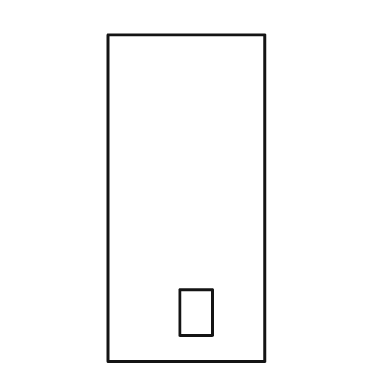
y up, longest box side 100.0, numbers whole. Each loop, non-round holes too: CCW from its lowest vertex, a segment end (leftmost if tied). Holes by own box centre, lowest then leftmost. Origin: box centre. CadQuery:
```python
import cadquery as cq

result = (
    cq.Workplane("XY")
    .moveTo(-24.0, -50.0)
    .lineTo(24.0, -50.0)
    .lineTo(24.0, 50.0)
    .lineTo(-24.0, 50.0)
    .close()
    .moveTo(-2.0, -42.0)
    .lineTo(8.0, -42.0)
    .lineTo(8.0, -28.0)
    .lineTo(-2.0, -28.0)
    .close()
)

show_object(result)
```